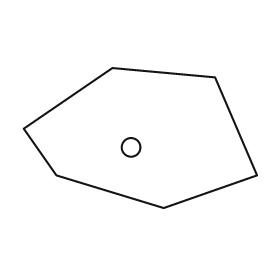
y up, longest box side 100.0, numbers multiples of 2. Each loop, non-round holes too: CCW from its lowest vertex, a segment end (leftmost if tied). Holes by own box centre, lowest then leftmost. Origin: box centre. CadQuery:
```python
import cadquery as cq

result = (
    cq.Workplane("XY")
    .moveTo(10.0, -30.0)
    .lineTo(50.0, -16.0)
    .lineTo(32.0, 26.0)
    .lineTo(-12.0, 30.0)
    .lineTo(-50.0, 4.0)
    .lineTo(-36.0, -16.0)
    .close()
    .moveTo(-4.0, -4.0)
    .circle(4.0)
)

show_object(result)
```